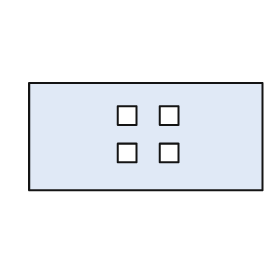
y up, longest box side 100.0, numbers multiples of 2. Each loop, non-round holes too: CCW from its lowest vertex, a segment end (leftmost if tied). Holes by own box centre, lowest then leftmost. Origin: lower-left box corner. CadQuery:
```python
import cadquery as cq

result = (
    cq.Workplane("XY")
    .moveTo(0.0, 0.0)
    .lineTo(100.0, 0.0)
    .lineTo(100.0, 46.0)
    .lineTo(0.0, 46.0)
    .close()
    .moveTo(38.0, 12.0)
    .lineTo(46.0, 12.0)
    .lineTo(46.0, 20.0)
    .lineTo(38.0, 20.0)
    .close()
    .moveTo(56.0, 12.0)
    .lineTo(64.0, 12.0)
    .lineTo(64.0, 20.0)
    .lineTo(56.0, 20.0)
    .close()
    .moveTo(38.0, 28.0)
    .lineTo(46.0, 28.0)
    .lineTo(46.0, 36.0)
    .lineTo(38.0, 36.0)
    .close()
    .moveTo(56.0, 28.0)
    .lineTo(64.0, 28.0)
    .lineTo(64.0, 36.0)
    .lineTo(56.0, 36.0)
    .close()
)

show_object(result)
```